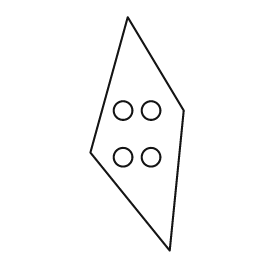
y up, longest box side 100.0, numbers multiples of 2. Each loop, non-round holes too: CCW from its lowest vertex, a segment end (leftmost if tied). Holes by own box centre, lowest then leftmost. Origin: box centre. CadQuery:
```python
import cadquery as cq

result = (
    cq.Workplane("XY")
    .moveTo(14.0, -50.0)
    .lineTo(20.0, 10.0)
    .lineTo(-4.0, 50.0)
    .lineTo(-20.0, -8.0)
    .close()
    .moveTo(-6.0, -10.0)
    .circle(4.0)
    .moveTo(6.0, -10.0)
    .circle(4.0)
    .moveTo(-6.0, 10.0)
    .circle(4.0)
    .moveTo(6.0, 10.0)
    .circle(4.0)
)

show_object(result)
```